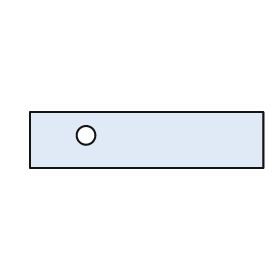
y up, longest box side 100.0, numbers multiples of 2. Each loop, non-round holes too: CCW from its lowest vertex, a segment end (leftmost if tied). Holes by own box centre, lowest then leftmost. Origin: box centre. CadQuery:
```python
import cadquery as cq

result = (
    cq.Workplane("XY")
    .moveTo(-50.0, -12.0)
    .lineTo(50.0, -12.0)
    .lineTo(50.0, 12.0)
    .lineTo(-50.0, 12.0)
    .close()
    .moveTo(-26.0, 2.0)
    .circle(4.0)
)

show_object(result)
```